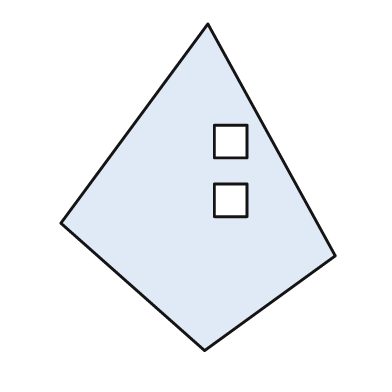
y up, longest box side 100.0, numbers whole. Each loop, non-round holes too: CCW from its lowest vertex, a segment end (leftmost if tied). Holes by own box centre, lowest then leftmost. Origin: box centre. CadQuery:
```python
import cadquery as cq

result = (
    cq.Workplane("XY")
    .moveTo(2.0, -50.0)
    .lineTo(42.0, -21.0)
    .lineTo(3.0, 50.0)
    .lineTo(-42.0, -11.0)
    .close()
    .moveTo(5.0, -9.0)
    .lineTo(15.0, -9.0)
    .lineTo(15.0, 1.0)
    .lineTo(5.0, 1.0)
    .close()
    .moveTo(5.0, 9.0)
    .lineTo(15.0, 9.0)
    .lineTo(15.0, 19.0)
    .lineTo(5.0, 19.0)
    .close()
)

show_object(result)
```